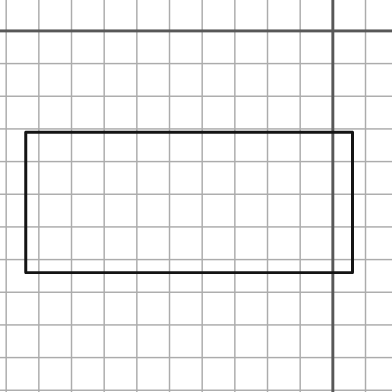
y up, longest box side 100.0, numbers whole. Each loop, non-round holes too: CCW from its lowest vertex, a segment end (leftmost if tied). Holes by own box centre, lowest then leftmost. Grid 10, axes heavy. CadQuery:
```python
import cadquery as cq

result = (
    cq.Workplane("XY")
    .moveTo(-94.0, -74.0)
    .lineTo(6.0, -74.0)
    .lineTo(6.0, -31.0)
    .lineTo(-94.0, -31.0)
    .close()
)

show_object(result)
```